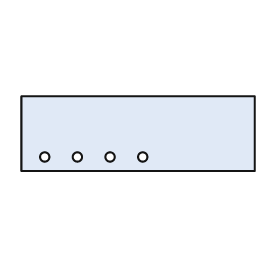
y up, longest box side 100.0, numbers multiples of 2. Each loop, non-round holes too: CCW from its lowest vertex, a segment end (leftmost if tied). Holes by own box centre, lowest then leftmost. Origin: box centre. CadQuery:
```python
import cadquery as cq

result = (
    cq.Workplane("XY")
    .moveTo(-50.0, -16.0)
    .lineTo(50.0, -16.0)
    .lineTo(50.0, 16.0)
    .lineTo(-50.0, 16.0)
    .close()
    .moveTo(-40.0, -10.0)
    .circle(2.0)
    .moveTo(-26.0, -10.0)
    .circle(2.0)
    .moveTo(-12.0, -10.0)
    .circle(2.0)
    .moveTo(2.0, -10.0)
    .circle(2.0)
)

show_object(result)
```